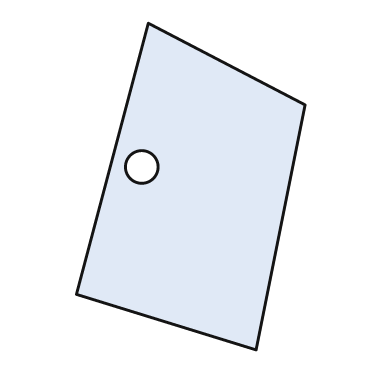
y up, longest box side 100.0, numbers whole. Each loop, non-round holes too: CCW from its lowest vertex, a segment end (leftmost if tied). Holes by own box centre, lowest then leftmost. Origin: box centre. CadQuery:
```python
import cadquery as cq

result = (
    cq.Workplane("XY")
    .moveTo(20.0, -50.0)
    .lineTo(35.0, 25.0)
    .lineTo(-13.0, 50.0)
    .lineTo(-35.0, -33.0)
    .close()
    .moveTo(-15.0, 6.0)
    .circle(5.0)
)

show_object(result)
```